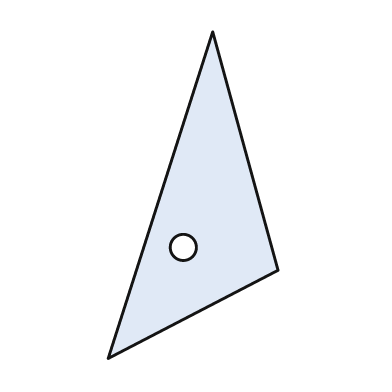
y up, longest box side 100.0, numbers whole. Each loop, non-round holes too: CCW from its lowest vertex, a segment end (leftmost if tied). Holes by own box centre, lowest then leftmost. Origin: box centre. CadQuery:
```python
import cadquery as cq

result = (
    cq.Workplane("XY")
    .moveTo(-26.0, -50.0)
    .lineTo(26.0, -23.0)
    .lineTo(6.0, 50.0)
    .close()
    .moveTo(-3.0, -16.0)
    .circle(4.0)
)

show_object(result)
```